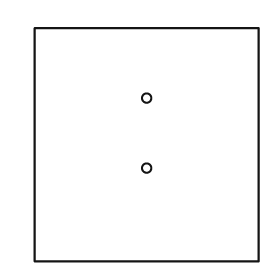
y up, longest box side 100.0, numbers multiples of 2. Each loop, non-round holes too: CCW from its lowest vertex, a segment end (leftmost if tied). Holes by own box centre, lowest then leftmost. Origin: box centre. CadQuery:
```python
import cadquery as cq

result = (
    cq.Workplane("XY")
    .moveTo(-48.0, -50.0)
    .lineTo(48.0, -50.0)
    .lineTo(48.0, 50.0)
    .lineTo(-48.0, 50.0)
    .close()
    .moveTo(0.0, -10.0)
    .circle(2.0)
    .moveTo(0.0, 20.0)
    .circle(2.0)
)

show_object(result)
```